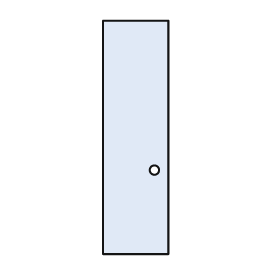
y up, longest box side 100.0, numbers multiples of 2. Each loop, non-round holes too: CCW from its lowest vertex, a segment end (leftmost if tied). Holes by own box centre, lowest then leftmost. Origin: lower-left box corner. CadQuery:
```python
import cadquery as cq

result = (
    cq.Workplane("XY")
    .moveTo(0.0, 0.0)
    .lineTo(28.0, 0.0)
    .lineTo(28.0, 100.0)
    .lineTo(0.0, 100.0)
    .close()
    .moveTo(22.0, 36.0)
    .circle(2.0)
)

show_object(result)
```